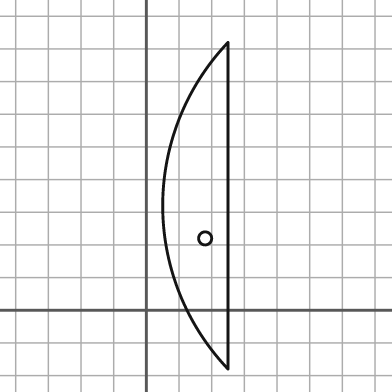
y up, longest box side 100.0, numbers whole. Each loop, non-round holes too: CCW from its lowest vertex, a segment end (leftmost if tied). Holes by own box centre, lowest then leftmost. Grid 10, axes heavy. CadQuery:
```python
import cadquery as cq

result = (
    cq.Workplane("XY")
    .moveTo(25.0, -18.0)
    .lineTo(25.0, 82.0)
    .threePointArc((5.0, 32.0), (25.0, -18.0))
    .close()
    .moveTo(18.0, 22.0)
    .circle(2.0)
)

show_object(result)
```